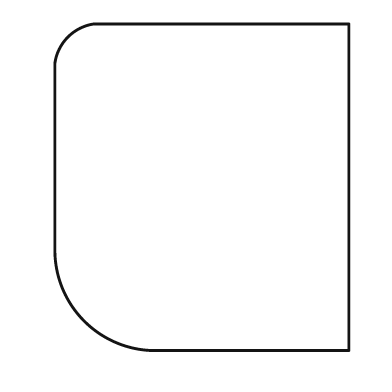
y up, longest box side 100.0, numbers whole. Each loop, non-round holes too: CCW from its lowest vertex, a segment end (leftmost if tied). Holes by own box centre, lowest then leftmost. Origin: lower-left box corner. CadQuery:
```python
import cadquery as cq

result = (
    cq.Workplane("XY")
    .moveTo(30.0, 0.0)
    .lineTo(90.0, 0.0)
    .lineTo(90.0, 100.0)
    .lineTo(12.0, 100.0)
    .threePointArc((4.0, 96.0), (0.0, 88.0))
    .lineTo(0.0, 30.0)
    .threePointArc((9.0, 9.0), (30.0, 0.0))
    .close()
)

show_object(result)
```